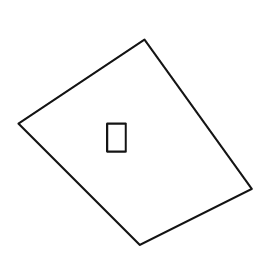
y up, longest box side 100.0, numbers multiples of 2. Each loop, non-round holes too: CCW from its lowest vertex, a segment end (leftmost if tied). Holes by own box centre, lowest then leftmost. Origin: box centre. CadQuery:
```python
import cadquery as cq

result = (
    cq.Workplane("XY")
    .moveTo(2.0, -44.0)
    .lineTo(50.0, -20.0)
    .lineTo(4.0, 44.0)
    .lineTo(-50.0, 8.0)
    .close()
    .moveTo(-12.0, -4.0)
    .lineTo(-4.0, -4.0)
    .lineTo(-4.0, 8.0)
    .lineTo(-12.0, 8.0)
    .close()
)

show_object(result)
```